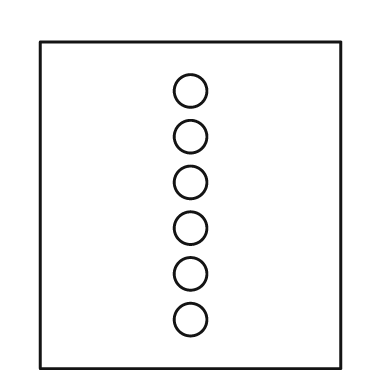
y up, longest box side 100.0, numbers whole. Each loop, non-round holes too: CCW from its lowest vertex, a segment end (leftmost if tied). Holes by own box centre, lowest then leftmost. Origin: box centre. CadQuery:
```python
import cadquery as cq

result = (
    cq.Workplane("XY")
    .moveTo(-46.0, -50.0)
    .lineTo(46.0, -50.0)
    .lineTo(46.0, 50.0)
    .lineTo(-46.0, 50.0)
    .close()
    .moveTo(0.0, -35.0)
    .circle(5.0)
    .moveTo(0.0, -21.0)
    .circle(5.0)
    .moveTo(0.0, -7.0)
    .circle(5.0)
    .moveTo(0.0, 7.0)
    .circle(5.0)
    .moveTo(0.0, 21.0)
    .circle(5.0)
    .moveTo(0.0, 35.0)
    .circle(5.0)
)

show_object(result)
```